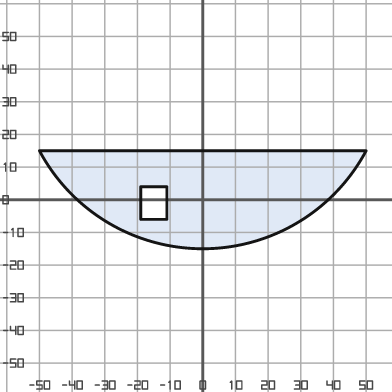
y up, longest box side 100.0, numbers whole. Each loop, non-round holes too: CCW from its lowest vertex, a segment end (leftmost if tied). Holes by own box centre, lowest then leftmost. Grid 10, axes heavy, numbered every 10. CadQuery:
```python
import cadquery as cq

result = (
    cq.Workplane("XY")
    .moveTo(-50.0, 15.0)
    .threePointArc((0.0, -15.0), (50.0, 15.0))
    .close()
    .moveTo(-19.0, -6.0)
    .lineTo(-11.0, -6.0)
    .lineTo(-11.0, 4.0)
    .lineTo(-19.0, 4.0)
    .close()
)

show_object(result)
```